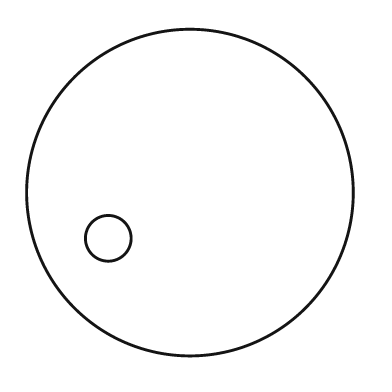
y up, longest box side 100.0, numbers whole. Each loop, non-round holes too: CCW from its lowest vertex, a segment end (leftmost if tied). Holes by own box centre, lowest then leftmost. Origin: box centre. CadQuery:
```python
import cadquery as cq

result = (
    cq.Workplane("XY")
    .moveTo(0.0, 0.0)
    .circle(50.0)
    .moveTo(-25.0, -14.0)
    .circle(7.0)
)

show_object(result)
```